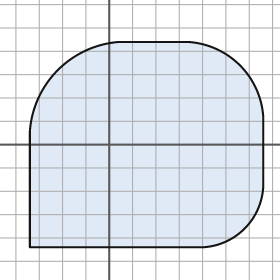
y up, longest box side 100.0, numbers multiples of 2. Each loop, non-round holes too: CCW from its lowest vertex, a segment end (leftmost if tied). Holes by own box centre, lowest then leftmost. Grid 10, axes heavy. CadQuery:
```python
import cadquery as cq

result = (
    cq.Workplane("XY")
    .moveTo(-34.0, -44.0)
    .lineTo(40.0, -44.0)
    .threePointArc((58.0, -36.0), (66.0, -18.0))
    .lineTo(66.0, 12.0)
    .threePointArc((56.0, 34.0), (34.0, 44.0))
    .lineTo(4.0, 44.0)
    .threePointArc((-22.0, 32.0), (-34.0, 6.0))
    .close()
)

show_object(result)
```